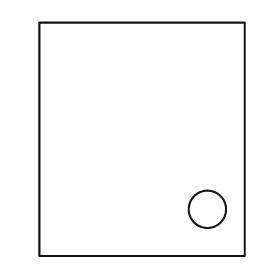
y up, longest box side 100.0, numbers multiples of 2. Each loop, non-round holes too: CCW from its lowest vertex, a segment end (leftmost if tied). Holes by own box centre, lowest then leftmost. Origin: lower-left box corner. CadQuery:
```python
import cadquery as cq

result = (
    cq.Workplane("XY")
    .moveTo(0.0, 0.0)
    .lineTo(88.0, 0.0)
    .lineTo(88.0, 100.0)
    .lineTo(0.0, 100.0)
    .close()
    .moveTo(72.0, 20.0)
    .circle(8.0)
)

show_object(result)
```